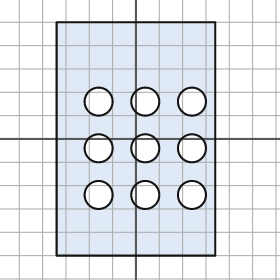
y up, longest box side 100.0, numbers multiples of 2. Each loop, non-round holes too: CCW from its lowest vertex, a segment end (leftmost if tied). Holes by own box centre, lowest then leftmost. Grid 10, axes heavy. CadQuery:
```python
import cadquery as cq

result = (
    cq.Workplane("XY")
    .moveTo(-34.0, -50.0)
    .lineTo(34.0, -50.0)
    .lineTo(34.0, 50.0)
    .lineTo(-34.0, 50.0)
    .close()
    .moveTo(-16.0, -24.0)
    .circle(6.0)
    .moveTo(4.0, -24.0)
    .circle(6.0)
    .moveTo(24.0, -24.0)
    .circle(6.0)
    .moveTo(-16.0, -4.0)
    .circle(6.0)
    .moveTo(4.0, -4.0)
    .circle(6.0)
    .moveTo(24.0, -4.0)
    .circle(6.0)
    .moveTo(-16.0, 16.0)
    .circle(6.0)
    .moveTo(4.0, 16.0)
    .circle(6.0)
    .moveTo(24.0, 16.0)
    .circle(6.0)
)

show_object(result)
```